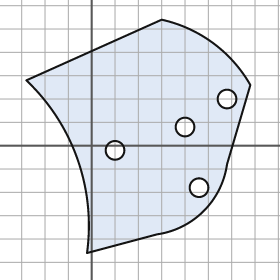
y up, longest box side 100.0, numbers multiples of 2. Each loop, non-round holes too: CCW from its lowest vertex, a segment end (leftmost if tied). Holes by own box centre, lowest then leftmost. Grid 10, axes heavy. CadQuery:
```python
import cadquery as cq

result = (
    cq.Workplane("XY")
    .moveTo(-2.0, -46.0)
    .lineTo(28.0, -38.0)
    .threePointArc((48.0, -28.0), (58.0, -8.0))
    .lineTo(68.0, 26.0)
    .threePointArc((52.0, 44.0), (30.0, 54.0))
    .lineTo(-28.0, 28.0)
    .threePointArc((-6.0, -6.0), (-2.0, -46.0))
    .close()
    .moveTo(46.0, -18.0)
    .circle(4.0)
    .moveTo(10.0, -2.0)
    .circle(4.0)
    .moveTo(40.0, 8.0)
    .circle(4.0)
    .moveTo(58.0, 20.0)
    .circle(4.0)
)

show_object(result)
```